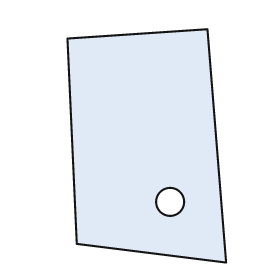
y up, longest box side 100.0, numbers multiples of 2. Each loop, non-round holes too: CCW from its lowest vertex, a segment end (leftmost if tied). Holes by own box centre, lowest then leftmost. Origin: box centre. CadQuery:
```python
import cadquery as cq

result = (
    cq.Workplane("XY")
    .moveTo(34.0, -50.0)
    .lineTo(26.0, 50.0)
    .lineTo(-34.0, 46.0)
    .lineTo(-30.0, -42.0)
    .close()
    .moveTo(10.0, -24.0)
    .circle(6.0)
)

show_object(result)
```